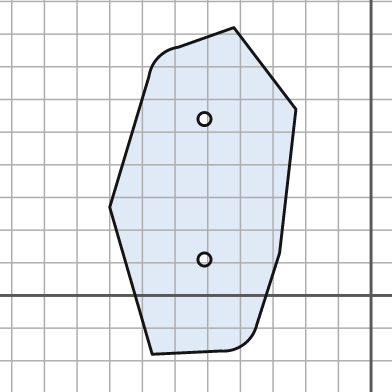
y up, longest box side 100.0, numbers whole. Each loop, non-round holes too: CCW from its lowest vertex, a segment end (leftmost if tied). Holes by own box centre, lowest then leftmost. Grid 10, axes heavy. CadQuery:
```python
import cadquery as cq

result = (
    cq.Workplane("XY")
    .moveTo(-67.0, -18.0)
    .lineTo(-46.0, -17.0)
    .threePointArc((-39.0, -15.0), (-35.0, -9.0))
    .lineTo(-28.0, 13.0)
    .lineTo(-23.0, 57.0)
    .lineTo(-42.0, 82.0)
    .lineTo(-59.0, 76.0)
    .threePointArc((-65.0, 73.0), (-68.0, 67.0))
    .lineTo(-80.0, 27.0)
    .close()
    .moveTo(-51.0, 11.0)
    .circle(2.0)
    .moveTo(-51.0, 54.0)
    .circle(2.0)
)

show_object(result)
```